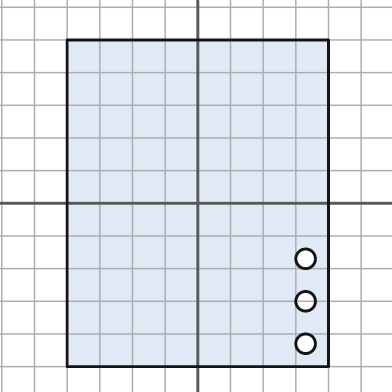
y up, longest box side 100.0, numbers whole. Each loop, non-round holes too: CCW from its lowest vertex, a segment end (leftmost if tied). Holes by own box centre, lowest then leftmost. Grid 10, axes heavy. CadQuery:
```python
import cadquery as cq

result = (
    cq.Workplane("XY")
    .moveTo(-40.0, -50.0)
    .lineTo(40.0, -50.0)
    .lineTo(40.0, 50.0)
    .lineTo(-40.0, 50.0)
    .close()
    .moveTo(33.0, -43.0)
    .circle(3.0)
    .moveTo(33.0, -30.0)
    .circle(3.0)
    .moveTo(33.0, -17.0)
    .circle(3.0)
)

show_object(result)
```